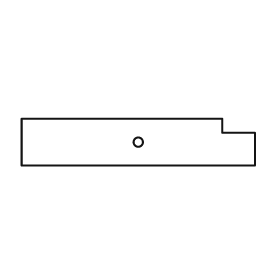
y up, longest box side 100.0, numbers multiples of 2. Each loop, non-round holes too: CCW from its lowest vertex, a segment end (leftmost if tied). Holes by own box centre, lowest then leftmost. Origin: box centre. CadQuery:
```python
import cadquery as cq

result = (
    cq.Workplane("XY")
    .moveTo(-50.0, -10.0)
    .lineTo(50.0, -10.0)
    .lineTo(50.0, 4.0)
    .lineTo(36.0, 4.0)
    .lineTo(36.0, 10.0)
    .lineTo(-50.0, 10.0)
    .close()
    .moveTo(0.0, 0.0)
    .circle(2.0)
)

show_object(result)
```